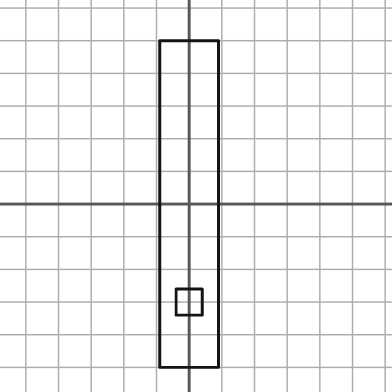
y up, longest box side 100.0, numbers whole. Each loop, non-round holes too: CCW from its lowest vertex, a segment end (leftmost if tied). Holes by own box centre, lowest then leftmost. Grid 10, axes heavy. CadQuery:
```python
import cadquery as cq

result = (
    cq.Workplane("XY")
    .moveTo(-9.0, -50.0)
    .lineTo(9.0, -50.0)
    .lineTo(9.0, 50.0)
    .lineTo(-9.0, 50.0)
    .close()
    .moveTo(-4.0, -34.0)
    .lineTo(4.0, -34.0)
    .lineTo(4.0, -26.0)
    .lineTo(-4.0, -26.0)
    .close()
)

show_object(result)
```